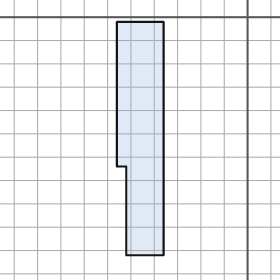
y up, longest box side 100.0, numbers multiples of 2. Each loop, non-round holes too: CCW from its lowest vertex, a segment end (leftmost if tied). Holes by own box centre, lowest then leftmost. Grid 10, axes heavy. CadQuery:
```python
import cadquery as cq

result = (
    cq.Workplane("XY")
    .moveTo(-52.0, -102.0)
    .lineTo(-36.0, -102.0)
    .lineTo(-36.0, -2.0)
    .lineTo(-56.0, -2.0)
    .lineTo(-56.0, -64.0)
    .lineTo(-52.0, -64.0)
    .close()
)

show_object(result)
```